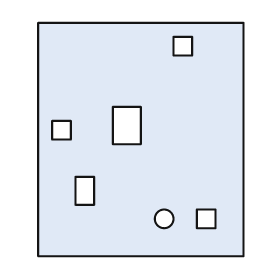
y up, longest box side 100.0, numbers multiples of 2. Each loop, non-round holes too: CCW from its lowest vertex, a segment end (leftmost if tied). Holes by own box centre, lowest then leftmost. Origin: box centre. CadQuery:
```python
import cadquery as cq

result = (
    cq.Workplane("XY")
    .moveTo(-44.0, -50.0)
    .lineTo(44.0, -50.0)
    .lineTo(44.0, 50.0)
    .lineTo(-44.0, 50.0)
    .close()
    .moveTo(10.0, -34.0)
    .circle(4.0)
    .moveTo(24.0, -38.0)
    .lineTo(32.0, -38.0)
    .lineTo(32.0, -30.0)
    .lineTo(24.0, -30.0)
    .close()
    .moveTo(-28.0, -28.0)
    .lineTo(-20.0, -28.0)
    .lineTo(-20.0, -16.0)
    .lineTo(-28.0, -16.0)
    .close()
    .moveTo(-38.0, 0.0)
    .lineTo(-30.0, 0.0)
    .lineTo(-30.0, 8.0)
    .lineTo(-38.0, 8.0)
    .close()
    .moveTo(-12.0, -2.0)
    .lineTo(0.0, -2.0)
    .lineTo(0.0, 14.0)
    .lineTo(-12.0, 14.0)
    .close()
    .moveTo(14.0, 36.0)
    .lineTo(22.0, 36.0)
    .lineTo(22.0, 44.0)
    .lineTo(14.0, 44.0)
    .close()
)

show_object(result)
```